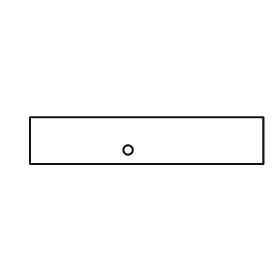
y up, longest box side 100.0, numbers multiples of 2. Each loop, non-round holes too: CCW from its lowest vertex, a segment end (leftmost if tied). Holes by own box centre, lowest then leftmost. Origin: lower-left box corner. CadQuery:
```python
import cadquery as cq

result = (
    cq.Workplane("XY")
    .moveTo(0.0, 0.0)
    .lineTo(100.0, 0.0)
    .lineTo(100.0, 20.0)
    .lineTo(0.0, 20.0)
    .close()
    .moveTo(42.0, 6.0)
    .circle(2.0)
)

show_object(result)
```